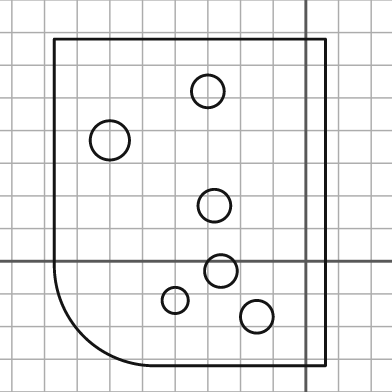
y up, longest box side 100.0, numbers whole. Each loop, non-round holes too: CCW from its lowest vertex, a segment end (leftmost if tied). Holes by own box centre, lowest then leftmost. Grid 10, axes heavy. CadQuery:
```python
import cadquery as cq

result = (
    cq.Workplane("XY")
    .moveTo(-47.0, -32.0)
    .lineTo(6.0, -32.0)
    .lineTo(6.0, 68.0)
    .lineTo(-77.0, 68.0)
    .lineTo(-77.0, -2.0)
    .threePointArc((-68.0, -23.0), (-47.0, -32.0))
    .close()
    .moveTo(-15.0, -17.0)
    .circle(5.0)
    .moveTo(-40.0, -12.0)
    .circle(4.0)
    .moveTo(-26.0, -3.0)
    .circle(5.0)
    .moveTo(-28.0, 17.0)
    .circle(5.0)
    .moveTo(-60.0, 37.0)
    .circle(6.0)
    .moveTo(-30.0, 52.0)
    .circle(5.0)
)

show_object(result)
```